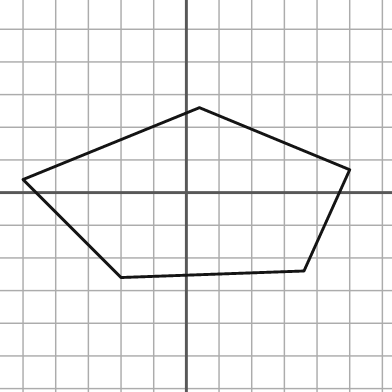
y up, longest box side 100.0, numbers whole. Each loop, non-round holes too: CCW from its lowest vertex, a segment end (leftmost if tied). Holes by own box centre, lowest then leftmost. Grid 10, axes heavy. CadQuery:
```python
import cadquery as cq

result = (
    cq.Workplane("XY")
    .moveTo(-20.0, -26.0)
    .lineTo(36.0, -24.0)
    .lineTo(50.0, 7.0)
    .lineTo(4.0, 26.0)
    .lineTo(-50.0, 4.0)
    .close()
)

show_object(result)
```